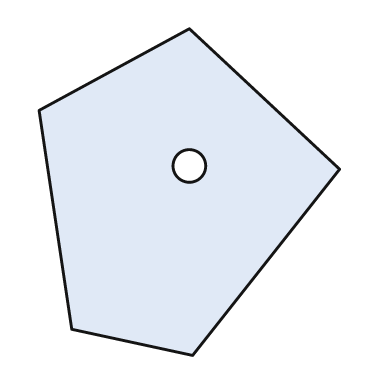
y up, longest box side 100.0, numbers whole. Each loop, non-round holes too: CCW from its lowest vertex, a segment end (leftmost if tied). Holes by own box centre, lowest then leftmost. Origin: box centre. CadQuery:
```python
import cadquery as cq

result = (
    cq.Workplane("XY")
    .moveTo(1.0, -50.0)
    .lineTo(46.0, 7.0)
    .lineTo(0.0, 50.0)
    .lineTo(-46.0, 25.0)
    .lineTo(-36.0, -42.0)
    .close()
    .moveTo(0.0, 8.0)
    .circle(5.0)
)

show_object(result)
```